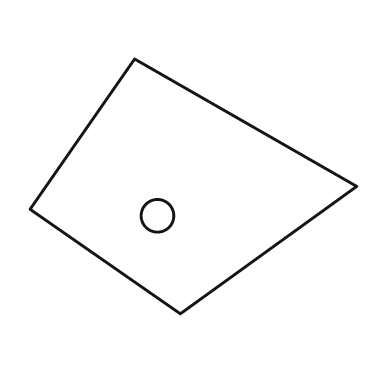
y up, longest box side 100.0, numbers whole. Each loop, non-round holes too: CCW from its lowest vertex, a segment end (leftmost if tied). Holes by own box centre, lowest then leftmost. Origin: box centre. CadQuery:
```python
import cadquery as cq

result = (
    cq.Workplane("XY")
    .moveTo(-4.0, -39.0)
    .lineTo(50.0, 0.0)
    .lineTo(-18.0, 39.0)
    .lineTo(-50.0, -7.0)
    .close()
    .moveTo(-11.0, -9.0)
    .circle(5.0)
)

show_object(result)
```